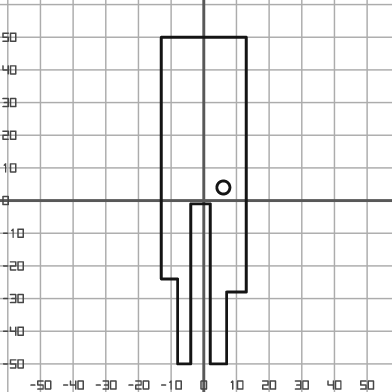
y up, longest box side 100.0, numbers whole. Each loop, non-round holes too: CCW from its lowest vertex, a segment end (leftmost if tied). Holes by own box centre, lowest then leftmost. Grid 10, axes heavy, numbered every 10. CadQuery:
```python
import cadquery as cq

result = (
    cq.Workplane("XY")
    .moveTo(-8.0, -50.0)
    .lineTo(-4.0, -50.0)
    .lineTo(-4.0, -1.0)
    .lineTo(2.0, -1.0)
    .lineTo(2.0, -50.0)
    .lineTo(7.0, -50.0)
    .lineTo(7.0, -28.0)
    .lineTo(13.0, -28.0)
    .lineTo(13.0, 50.0)
    .lineTo(-13.0, 50.0)
    .lineTo(-13.0, -24.0)
    .lineTo(-8.0, -24.0)
    .close()
    .moveTo(6.0, 4.0)
    .circle(2.0)
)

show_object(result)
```